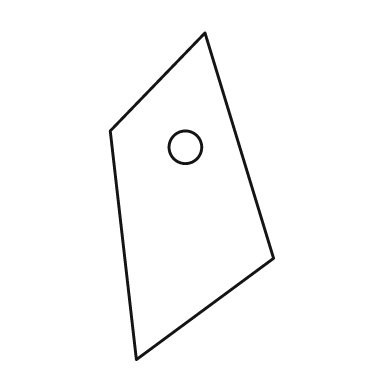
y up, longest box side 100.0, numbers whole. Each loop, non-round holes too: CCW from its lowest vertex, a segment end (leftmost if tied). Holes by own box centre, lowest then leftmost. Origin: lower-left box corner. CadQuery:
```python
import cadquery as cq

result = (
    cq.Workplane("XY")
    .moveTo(8.0, 0.0)
    .lineTo(50.0, 31.0)
    .lineTo(29.0, 100.0)
    .lineTo(0.0, 70.0)
    .close()
    .moveTo(23.0, 65.0)
    .circle(5.0)
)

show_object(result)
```